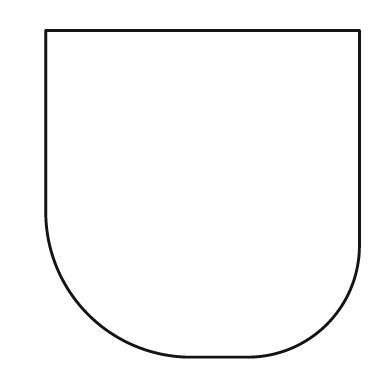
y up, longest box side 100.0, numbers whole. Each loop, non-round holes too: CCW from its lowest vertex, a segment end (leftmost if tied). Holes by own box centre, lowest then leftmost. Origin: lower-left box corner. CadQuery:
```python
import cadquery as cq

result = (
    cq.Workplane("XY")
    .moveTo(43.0, 0.0)
    .lineTo(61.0, 0.0)
    .threePointArc((86.0, 10.0), (96.0, 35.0))
    .lineTo(96.0, 100.0)
    .lineTo(0.0, 100.0)
    .lineTo(0.0, 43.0)
    .threePointArc((13.0, 13.0), (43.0, 0.0))
    .close()
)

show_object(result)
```